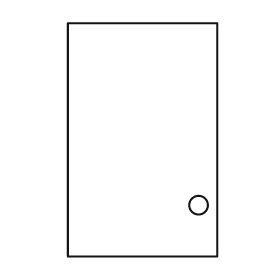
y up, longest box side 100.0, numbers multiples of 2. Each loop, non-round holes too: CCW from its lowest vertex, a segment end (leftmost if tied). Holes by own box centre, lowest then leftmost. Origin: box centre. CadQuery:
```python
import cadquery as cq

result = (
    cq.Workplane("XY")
    .moveTo(-32.0, -50.0)
    .lineTo(32.0, -50.0)
    .lineTo(32.0, 50.0)
    .lineTo(-32.0, 50.0)
    .close()
    .moveTo(24.0, -28.0)
    .circle(4.0)
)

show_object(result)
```